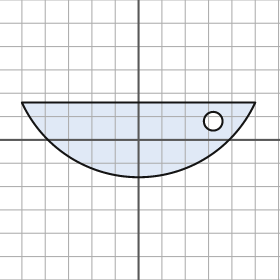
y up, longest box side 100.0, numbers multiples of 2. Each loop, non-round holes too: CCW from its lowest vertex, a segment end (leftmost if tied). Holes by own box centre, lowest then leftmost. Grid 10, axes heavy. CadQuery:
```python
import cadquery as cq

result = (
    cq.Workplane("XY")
    .moveTo(-50.0, 16.0)
    .threePointArc((0.0, -16.0), (50.0, 16.0))
    .close()
    .moveTo(32.0, 8.0)
    .circle(4.0)
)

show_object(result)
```